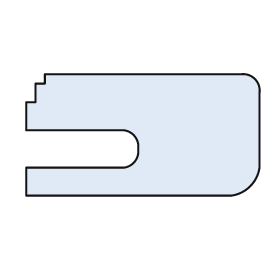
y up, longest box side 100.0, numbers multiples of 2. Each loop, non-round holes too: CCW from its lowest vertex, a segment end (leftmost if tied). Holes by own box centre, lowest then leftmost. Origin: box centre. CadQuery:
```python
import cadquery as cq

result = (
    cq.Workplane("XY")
    .moveTo(-50.0, -26.0)
    .lineTo(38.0, -26.0)
    .threePointArc((46.0, -22.0), (50.0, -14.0))
    .lineTo(50.0, 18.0)
    .threePointArc((48.0, 24.0), (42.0, 26.0))
    .lineTo(-42.0, 26.0)
    .lineTo(-42.0, 22.0)
    .lineTo(-46.0, 22.0)
    .lineTo(-46.0, 14.0)
    .lineTo(-50.0, 14.0)
    .lineTo(-50.0, 2.0)
    .lineTo(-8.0, 2.0)
    .threePointArc((-4.0, 0.0), (-2.0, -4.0))
    .lineTo(-2.0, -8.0)
    .threePointArc((-4.0, -12.0), (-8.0, -14.0))
    .lineTo(-50.0, -14.0)
    .close()
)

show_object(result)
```